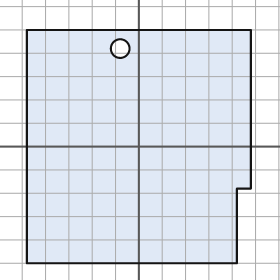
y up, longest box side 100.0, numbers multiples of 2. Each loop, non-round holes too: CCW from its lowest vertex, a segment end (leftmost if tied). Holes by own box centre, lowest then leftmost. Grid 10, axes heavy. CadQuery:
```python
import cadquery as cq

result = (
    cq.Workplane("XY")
    .moveTo(-48.0, -50.0)
    .lineTo(42.0, -50.0)
    .lineTo(42.0, -18.0)
    .lineTo(48.0, -18.0)
    .lineTo(48.0, 50.0)
    .lineTo(-48.0, 50.0)
    .close()
    .moveTo(-8.0, 42.0)
    .circle(4.0)
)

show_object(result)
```